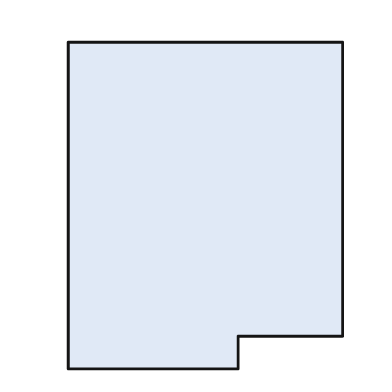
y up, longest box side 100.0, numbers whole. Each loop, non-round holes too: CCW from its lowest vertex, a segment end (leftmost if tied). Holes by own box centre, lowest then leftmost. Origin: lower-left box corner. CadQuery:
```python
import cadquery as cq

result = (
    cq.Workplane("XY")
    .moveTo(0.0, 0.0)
    .lineTo(52.0, 0.0)
    .lineTo(52.0, 10.0)
    .lineTo(84.0, 10.0)
    .lineTo(84.0, 100.0)
    .lineTo(0.0, 100.0)
    .close()
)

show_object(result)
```